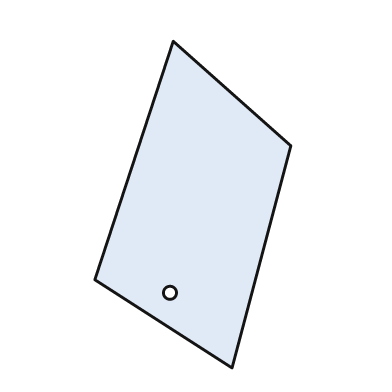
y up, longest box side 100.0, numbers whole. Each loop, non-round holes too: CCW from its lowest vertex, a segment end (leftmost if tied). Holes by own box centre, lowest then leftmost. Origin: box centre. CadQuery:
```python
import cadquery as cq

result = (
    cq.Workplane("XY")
    .moveTo(12.0, -50.0)
    .lineTo(30.0, 18.0)
    .lineTo(-6.0, 50.0)
    .lineTo(-30.0, -23.0)
    .close()
    .moveTo(-7.0, -27.0)
    .circle(2.0)
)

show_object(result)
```